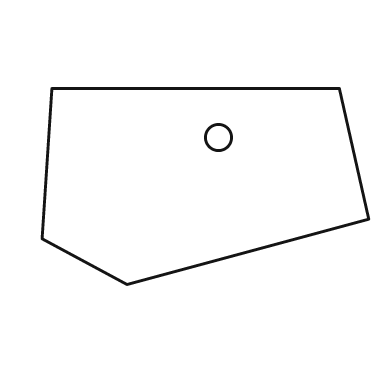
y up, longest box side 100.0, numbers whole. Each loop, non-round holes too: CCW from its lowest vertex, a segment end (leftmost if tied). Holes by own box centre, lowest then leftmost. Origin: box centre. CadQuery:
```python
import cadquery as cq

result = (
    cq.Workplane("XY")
    .moveTo(-24.0, -30.0)
    .lineTo(50.0, -10.0)
    .lineTo(41.0, 30.0)
    .lineTo(-47.0, 30.0)
    .lineTo(-50.0, -16.0)
    .close()
    .moveTo(4.0, 15.0)
    .circle(4.0)
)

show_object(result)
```